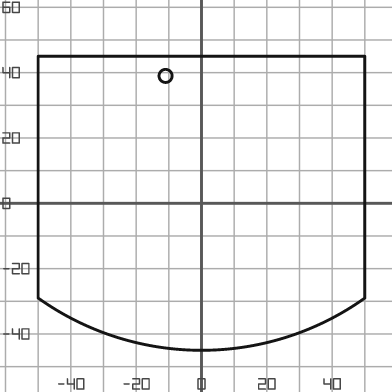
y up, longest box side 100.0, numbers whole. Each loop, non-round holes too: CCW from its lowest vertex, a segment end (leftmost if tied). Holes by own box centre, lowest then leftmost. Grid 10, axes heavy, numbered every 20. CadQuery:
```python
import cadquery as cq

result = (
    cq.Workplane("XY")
    .moveTo(-50.0, -29.0)
    .threePointArc((0.0, -45.0), (50.0, -29.0))
    .lineTo(50.0, 45.0)
    .lineTo(-50.0, 45.0)
    .close()
    .moveTo(-11.0, 39.0)
    .circle(2.0)
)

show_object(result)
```